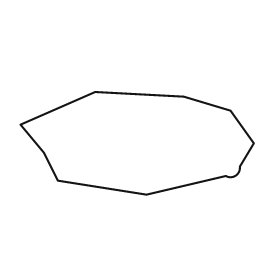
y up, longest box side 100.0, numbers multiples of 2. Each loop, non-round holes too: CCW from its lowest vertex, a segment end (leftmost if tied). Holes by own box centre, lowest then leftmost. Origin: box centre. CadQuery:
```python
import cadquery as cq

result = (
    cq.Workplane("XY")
    .moveTo(4.0, -22.0)
    .lineTo(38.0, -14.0)
    .threePointArc((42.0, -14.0), (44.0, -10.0))
    .lineTo(50.0, 0.0)
    .lineTo(40.0, 14.0)
    .lineTo(20.0, 20.0)
    .lineTo(-18.0, 22.0)
    .lineTo(-50.0, 8.0)
    .lineTo(-40.0, -4.0)
    .lineTo(-34.0, -16.0)
    .close()
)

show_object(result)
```